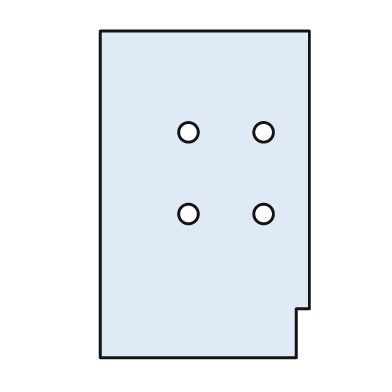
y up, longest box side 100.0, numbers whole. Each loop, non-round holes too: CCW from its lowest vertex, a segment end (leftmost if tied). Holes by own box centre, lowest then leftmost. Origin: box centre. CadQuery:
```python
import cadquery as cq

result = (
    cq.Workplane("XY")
    .moveTo(-32.0, -50.0)
    .lineTo(28.0, -50.0)
    .lineTo(28.0, -35.0)
    .lineTo(32.0, -35.0)
    .lineTo(32.0, 50.0)
    .lineTo(-32.0, 50.0)
    .close()
    .moveTo(-5.0, -6.0)
    .circle(3.0)
    .moveTo(18.0, -6.0)
    .circle(3.0)
    .moveTo(-5.0, 19.0)
    .circle(3.0)
    .moveTo(18.0, 19.0)
    .circle(3.0)
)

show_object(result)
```